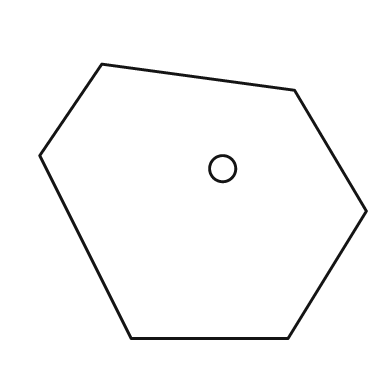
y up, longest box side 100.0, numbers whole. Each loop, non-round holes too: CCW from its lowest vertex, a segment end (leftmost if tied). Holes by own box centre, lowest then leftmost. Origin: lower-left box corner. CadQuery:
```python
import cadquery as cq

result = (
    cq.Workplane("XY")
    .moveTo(28.0, 0.0)
    .lineTo(76.0, 0.0)
    .lineTo(100.0, 39.0)
    .lineTo(78.0, 76.0)
    .lineTo(19.0, 84.0)
    .lineTo(0.0, 56.0)
    .close()
    .moveTo(56.0, 52.0)
    .circle(4.0)
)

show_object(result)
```